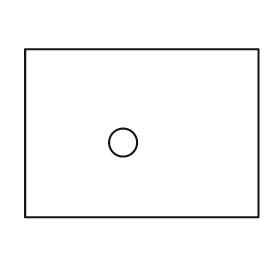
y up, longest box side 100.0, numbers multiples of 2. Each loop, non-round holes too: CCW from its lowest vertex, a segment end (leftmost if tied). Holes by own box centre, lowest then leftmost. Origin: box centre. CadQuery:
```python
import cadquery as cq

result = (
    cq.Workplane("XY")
    .moveTo(-50.0, -36.0)
    .lineTo(50.0, -36.0)
    .lineTo(50.0, 36.0)
    .lineTo(-50.0, 36.0)
    .close()
    .moveTo(-8.0, -4.0)
    .circle(6.0)
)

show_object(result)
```